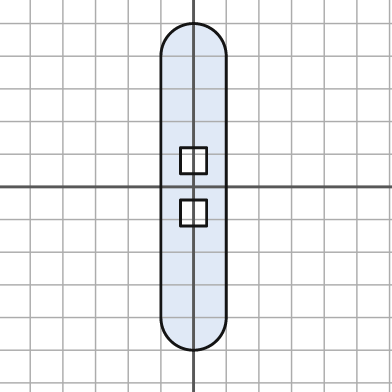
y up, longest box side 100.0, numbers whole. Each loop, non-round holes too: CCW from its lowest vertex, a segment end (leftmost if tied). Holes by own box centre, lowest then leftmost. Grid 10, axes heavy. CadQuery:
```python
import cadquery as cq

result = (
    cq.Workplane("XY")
    .moveTo(-10.0, -40.0)
    .threePointArc((0.0, -50.0), (10.0, -40.0))
    .lineTo(10.0, 40.0)
    .threePointArc((0.0, 50.0), (-10.0, 40.0))
    .close()
    .moveTo(-4.0, -12.0)
    .lineTo(4.0, -12.0)
    .lineTo(4.0, -4.0)
    .lineTo(-4.0, -4.0)
    .close()
    .moveTo(-4.0, 4.0)
    .lineTo(4.0, 4.0)
    .lineTo(4.0, 12.0)
    .lineTo(-4.0, 12.0)
    .close()
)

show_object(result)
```